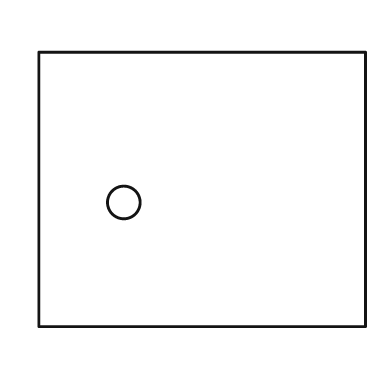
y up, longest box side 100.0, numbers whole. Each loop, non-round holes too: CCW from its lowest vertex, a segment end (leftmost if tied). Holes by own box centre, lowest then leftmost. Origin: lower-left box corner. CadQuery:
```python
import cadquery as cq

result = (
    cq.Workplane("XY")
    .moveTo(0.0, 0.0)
    .lineTo(100.0, 0.0)
    .lineTo(100.0, 84.0)
    .lineTo(0.0, 84.0)
    .close()
    .moveTo(26.0, 38.0)
    .circle(5.0)
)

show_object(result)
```